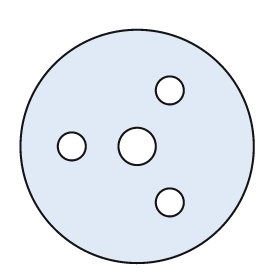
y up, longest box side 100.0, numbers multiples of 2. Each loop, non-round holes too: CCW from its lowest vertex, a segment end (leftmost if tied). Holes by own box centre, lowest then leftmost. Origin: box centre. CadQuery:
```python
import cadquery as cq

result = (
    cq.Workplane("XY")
    .moveTo(0.0, 0.0)
    .circle(50.0)
    .moveTo(14.0, -24.0)
    .circle(6.0)
    .moveTo(-28.0, 0.0)
    .circle(6.0)
    .moveTo(0.0, 0.0)
    .circle(8.0)
    .moveTo(14.0, 24.0)
    .circle(6.0)
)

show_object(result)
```